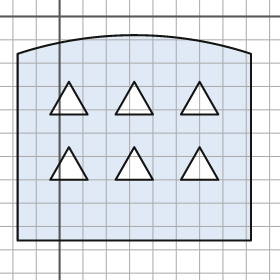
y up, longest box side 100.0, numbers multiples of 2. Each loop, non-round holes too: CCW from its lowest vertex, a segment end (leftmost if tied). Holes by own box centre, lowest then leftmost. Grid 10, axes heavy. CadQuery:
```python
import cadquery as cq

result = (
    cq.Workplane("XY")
    .moveTo(-18.0, -96.0)
    .lineTo(82.0, -96.0)
    .lineTo(82.0, -16.0)
    .threePointArc((32.0, -8.0), (-18.0, -16.0))
    .close()
    .moveTo(-4.0, -70.0)
    .lineTo(12.0, -70.0)
    .lineTo(4.0, -56.0)
    .close()
    .moveTo(24.0, -70.0)
    .lineTo(40.0, -70.0)
    .lineTo(32.0, -56.0)
    .close()
    .moveTo(52.0, -70.0)
    .lineTo(68.0, -70.0)
    .lineTo(60.0, -56.0)
    .close()
    .moveTo(-4.0, -42.0)
    .lineTo(12.0, -42.0)
    .lineTo(4.0, -28.0)
    .close()
    .moveTo(24.0, -42.0)
    .lineTo(40.0, -42.0)
    .lineTo(32.0, -28.0)
    .close()
    .moveTo(52.0, -42.0)
    .lineTo(68.0, -42.0)
    .lineTo(60.0, -28.0)
    .close()
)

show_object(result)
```